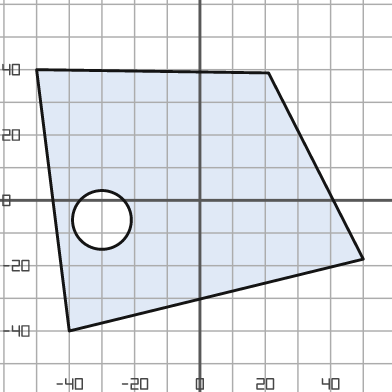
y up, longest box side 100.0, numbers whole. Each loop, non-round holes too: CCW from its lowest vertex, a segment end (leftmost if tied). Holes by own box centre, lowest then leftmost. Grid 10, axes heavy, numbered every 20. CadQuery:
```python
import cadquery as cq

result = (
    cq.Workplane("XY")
    .moveTo(-40.0, -40.0)
    .lineTo(50.0, -18.0)
    .lineTo(21.0, 39.0)
    .lineTo(-50.0, 40.0)
    .close()
    .moveTo(-30.0, -6.0)
    .circle(9.0)
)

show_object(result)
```